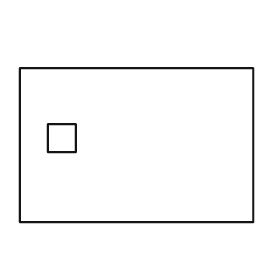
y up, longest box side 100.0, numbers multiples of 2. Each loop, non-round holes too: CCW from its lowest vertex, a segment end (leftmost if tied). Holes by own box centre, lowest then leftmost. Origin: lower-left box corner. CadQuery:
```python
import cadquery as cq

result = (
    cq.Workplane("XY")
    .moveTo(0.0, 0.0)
    .lineTo(100.0, 0.0)
    .lineTo(100.0, 66.0)
    .lineTo(0.0, 66.0)
    .close()
    .moveTo(12.0, 30.0)
    .lineTo(24.0, 30.0)
    .lineTo(24.0, 42.0)
    .lineTo(12.0, 42.0)
    .close()
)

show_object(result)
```